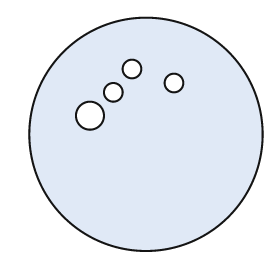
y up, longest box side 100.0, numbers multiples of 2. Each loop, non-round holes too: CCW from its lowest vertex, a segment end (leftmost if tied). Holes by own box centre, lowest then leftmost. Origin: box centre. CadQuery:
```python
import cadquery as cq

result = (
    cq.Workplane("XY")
    .moveTo(0.0, 0.0)
    .circle(50.0)
    .moveTo(-24.0, 8.0)
    .circle(6.0)
    .moveTo(-14.0, 18.0)
    .circle(4.0)
    .moveTo(12.0, 22.0)
    .circle(4.0)
    .moveTo(-6.0, 28.0)
    .circle(4.0)
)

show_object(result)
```